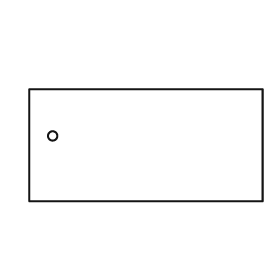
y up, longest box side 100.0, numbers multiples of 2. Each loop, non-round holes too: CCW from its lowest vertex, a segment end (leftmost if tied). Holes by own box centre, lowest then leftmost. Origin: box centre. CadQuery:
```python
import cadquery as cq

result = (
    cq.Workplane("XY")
    .moveTo(-50.0, -24.0)
    .lineTo(50.0, -24.0)
    .lineTo(50.0, 24.0)
    .lineTo(-50.0, 24.0)
    .close()
    .moveTo(-40.0, 4.0)
    .circle(2.0)
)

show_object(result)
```